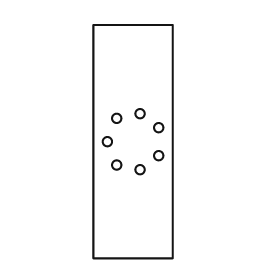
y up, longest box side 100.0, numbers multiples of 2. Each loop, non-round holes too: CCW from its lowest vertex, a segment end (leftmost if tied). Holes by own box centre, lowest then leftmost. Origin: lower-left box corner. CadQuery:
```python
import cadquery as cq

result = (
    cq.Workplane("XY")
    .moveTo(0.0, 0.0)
    .lineTo(34.0, 0.0)
    .lineTo(34.0, 100.0)
    .lineTo(0.0, 100.0)
    .close()
    .moveTo(20.0, 38.0)
    .circle(2.0)
    .moveTo(10.0, 40.0)
    .circle(2.0)
    .moveTo(28.0, 44.0)
    .circle(2.0)
    .moveTo(6.0, 50.0)
    .circle(2.0)
    .moveTo(28.0, 56.0)
    .circle(2.0)
    .moveTo(10.0, 60.0)
    .circle(2.0)
    .moveTo(20.0, 62.0)
    .circle(2.0)
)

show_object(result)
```